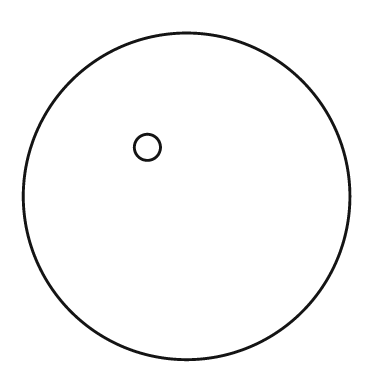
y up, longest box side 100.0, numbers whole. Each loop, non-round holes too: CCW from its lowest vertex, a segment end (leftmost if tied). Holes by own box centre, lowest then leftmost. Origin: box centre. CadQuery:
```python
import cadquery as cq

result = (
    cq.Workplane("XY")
    .moveTo(0.0, 0.0)
    .circle(50.0)
    .moveTo(-12.0, 15.0)
    .circle(4.0)
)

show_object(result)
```